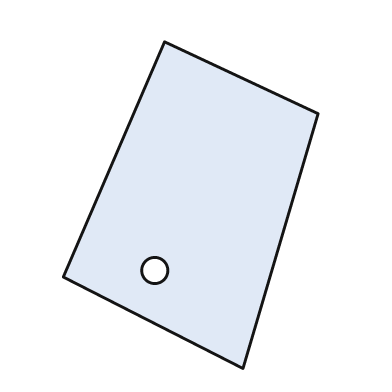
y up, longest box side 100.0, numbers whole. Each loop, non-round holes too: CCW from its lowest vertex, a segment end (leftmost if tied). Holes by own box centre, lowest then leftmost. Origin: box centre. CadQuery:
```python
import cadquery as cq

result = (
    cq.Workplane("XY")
    .moveTo(16.0, -50.0)
    .lineTo(39.0, 28.0)
    .lineTo(-8.0, 50.0)
    .lineTo(-39.0, -22.0)
    .close()
    .moveTo(-11.0, -20.0)
    .circle(4.0)
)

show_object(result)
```